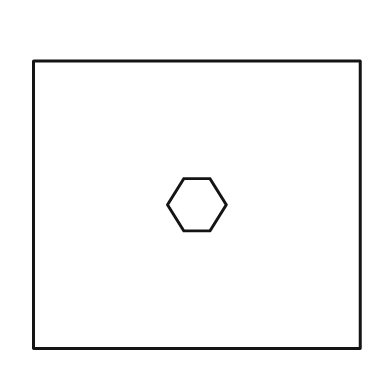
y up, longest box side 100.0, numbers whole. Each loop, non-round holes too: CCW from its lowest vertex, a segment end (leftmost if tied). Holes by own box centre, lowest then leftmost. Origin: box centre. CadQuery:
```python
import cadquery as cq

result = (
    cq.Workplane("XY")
    .moveTo(-50.0, -44.0)
    .lineTo(50.0, -44.0)
    .lineTo(50.0, 44.0)
    .lineTo(-50.0, 44.0)
    .close()
    .moveTo(-4.0, -8.0)
    .lineTo(4.0, -8.0)
    .lineTo(9.0, 0.0)
    .lineTo(4.0, 8.0)
    .lineTo(-4.0, 8.0)
    .lineTo(-9.0, 0.0)
    .close()
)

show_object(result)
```